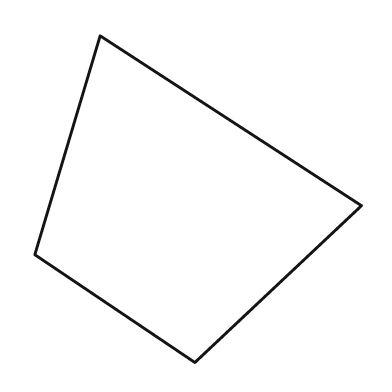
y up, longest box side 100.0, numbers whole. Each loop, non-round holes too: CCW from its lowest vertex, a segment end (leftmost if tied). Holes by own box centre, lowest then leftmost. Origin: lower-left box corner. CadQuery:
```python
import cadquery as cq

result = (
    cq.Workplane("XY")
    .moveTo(49.0, 0.0)
    .lineTo(100.0, 48.0)
    .lineTo(20.0, 100.0)
    .lineTo(0.0, 33.0)
    .close()
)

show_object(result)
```